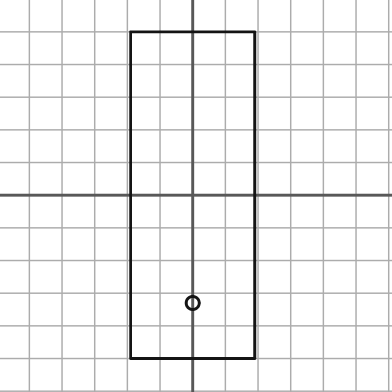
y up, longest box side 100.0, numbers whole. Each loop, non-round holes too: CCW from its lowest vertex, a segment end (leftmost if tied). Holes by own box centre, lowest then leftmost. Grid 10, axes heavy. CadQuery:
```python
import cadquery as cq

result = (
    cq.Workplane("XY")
    .moveTo(-19.0, -50.0)
    .lineTo(19.0, -50.0)
    .lineTo(19.0, 50.0)
    .lineTo(-19.0, 50.0)
    .close()
    .moveTo(0.0, -33.0)
    .circle(2.0)
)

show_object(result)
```